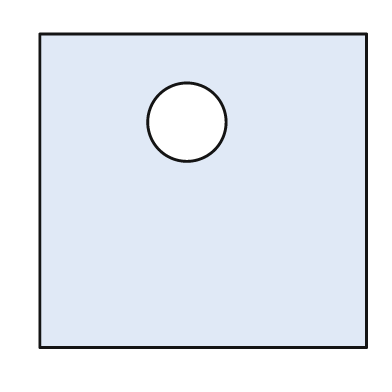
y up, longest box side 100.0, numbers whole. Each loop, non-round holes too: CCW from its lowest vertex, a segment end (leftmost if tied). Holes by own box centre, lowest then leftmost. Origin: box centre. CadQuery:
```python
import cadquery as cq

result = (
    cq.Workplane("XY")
    .moveTo(-50.0, -48.0)
    .lineTo(50.0, -48.0)
    .lineTo(50.0, 48.0)
    .lineTo(-50.0, 48.0)
    .close()
    .moveTo(-5.0, 21.0)
    .circle(12.0)
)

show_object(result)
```